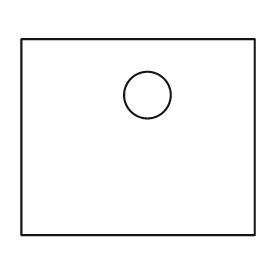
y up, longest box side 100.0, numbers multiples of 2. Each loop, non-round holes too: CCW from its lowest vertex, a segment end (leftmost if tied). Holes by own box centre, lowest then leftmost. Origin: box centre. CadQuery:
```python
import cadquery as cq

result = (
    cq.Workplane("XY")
    .moveTo(-50.0, -42.0)
    .lineTo(50.0, -42.0)
    .lineTo(50.0, 42.0)
    .lineTo(-50.0, 42.0)
    .close()
    .moveTo(4.0, 18.0)
    .circle(10.0)
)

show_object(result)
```